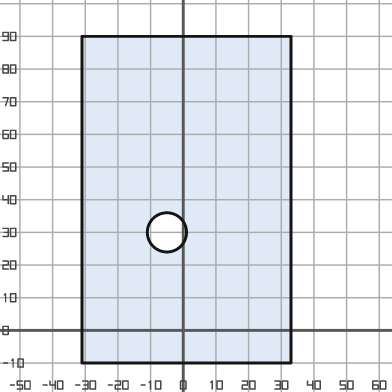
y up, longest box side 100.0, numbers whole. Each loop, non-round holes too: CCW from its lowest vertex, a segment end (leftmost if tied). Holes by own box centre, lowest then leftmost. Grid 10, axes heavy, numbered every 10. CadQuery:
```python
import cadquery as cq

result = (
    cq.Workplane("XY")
    .moveTo(-31.0, -10.0)
    .lineTo(33.0, -10.0)
    .lineTo(33.0, 90.0)
    .lineTo(-31.0, 90.0)
    .close()
    .moveTo(-5.0, 30.0)
    .circle(6.0)
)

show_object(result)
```